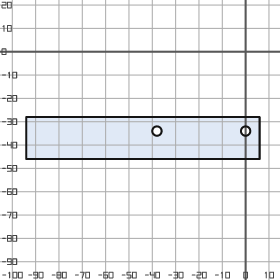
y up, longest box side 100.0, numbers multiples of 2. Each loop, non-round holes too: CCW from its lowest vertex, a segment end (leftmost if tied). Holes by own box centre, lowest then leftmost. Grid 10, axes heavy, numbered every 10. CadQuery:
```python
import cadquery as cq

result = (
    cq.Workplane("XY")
    .moveTo(-94.0, -46.0)
    .lineTo(6.0, -46.0)
    .lineTo(6.0, -28.0)
    .lineTo(-94.0, -28.0)
    .close()
    .moveTo(-38.0, -34.0)
    .circle(2.0)
    .moveTo(0.0, -34.0)
    .circle(2.0)
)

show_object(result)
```